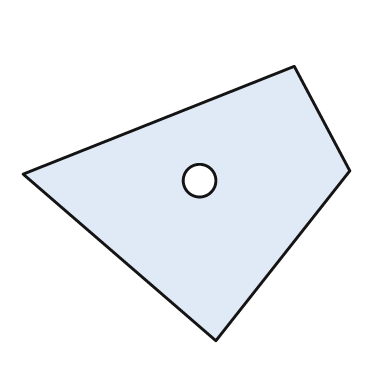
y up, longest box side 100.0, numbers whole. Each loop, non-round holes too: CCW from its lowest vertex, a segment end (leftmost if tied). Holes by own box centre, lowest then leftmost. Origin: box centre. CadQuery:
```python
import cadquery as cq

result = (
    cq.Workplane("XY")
    .moveTo(9.0, -42.0)
    .lineTo(50.0, 10.0)
    .lineTo(33.0, 42.0)
    .lineTo(-50.0, 9.0)
    .close()
    .moveTo(4.0, 7.0)
    .circle(5.0)
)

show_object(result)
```